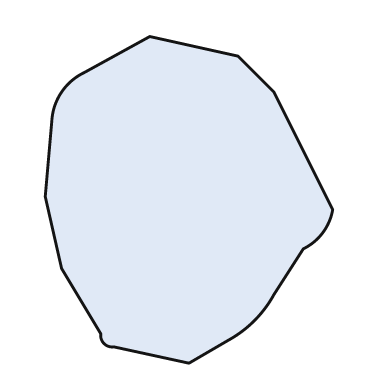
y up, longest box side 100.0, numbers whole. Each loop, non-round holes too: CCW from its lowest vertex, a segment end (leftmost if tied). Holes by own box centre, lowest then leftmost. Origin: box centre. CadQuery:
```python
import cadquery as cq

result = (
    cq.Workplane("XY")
    .moveTo(0.0, -50.0)
    .lineTo(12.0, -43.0)
    .threePointArc((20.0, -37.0), (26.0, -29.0))
    .lineTo(35.0, -15.0)
    .threePointArc((41.0, -10.0), (44.0, -3.0))
    .lineTo(26.0, 33.0)
    .lineTo(15.0, 44.0)
    .lineTo(-12.0, 50.0)
    .lineTo(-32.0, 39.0)
    .threePointArc((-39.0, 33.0), (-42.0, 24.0))
    .lineTo(-44.0, 1.0)
    .lineTo(-39.0, -21.0)
    .lineTo(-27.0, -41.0)
    .threePointArc((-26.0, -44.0), (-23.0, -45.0))
    .close()
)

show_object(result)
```